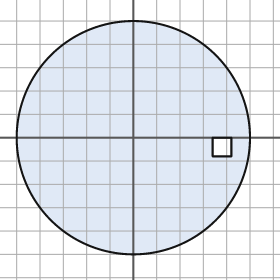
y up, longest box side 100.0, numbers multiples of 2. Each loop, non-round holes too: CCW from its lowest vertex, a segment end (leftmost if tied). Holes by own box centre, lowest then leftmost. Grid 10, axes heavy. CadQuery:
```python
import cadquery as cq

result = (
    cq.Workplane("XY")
    .moveTo(0.0, 0.0)
    .circle(50.0)
    .moveTo(34.0, -8.0)
    .lineTo(42.0, -8.0)
    .lineTo(42.0, 0.0)
    .lineTo(34.0, 0.0)
    .close()
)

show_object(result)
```